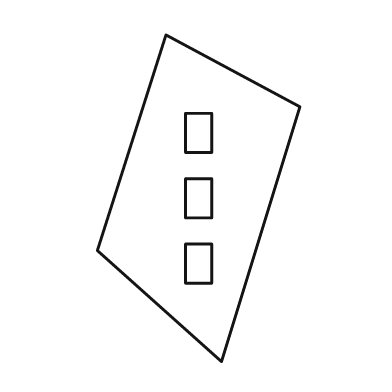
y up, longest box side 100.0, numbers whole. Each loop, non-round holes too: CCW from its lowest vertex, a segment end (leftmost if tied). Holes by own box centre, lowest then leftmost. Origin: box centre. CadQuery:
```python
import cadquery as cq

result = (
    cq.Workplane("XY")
    .moveTo(7.0, -50.0)
    .lineTo(31.0, 28.0)
    .lineTo(-10.0, 50.0)
    .lineTo(-31.0, -16.0)
    .close()
    .moveTo(-4.0, -26.0)
    .lineTo(4.0, -26.0)
    .lineTo(4.0, -14.0)
    .lineTo(-4.0, -14.0)
    .close()
    .moveTo(-4.0, -6.0)
    .lineTo(4.0, -6.0)
    .lineTo(4.0, 6.0)
    .lineTo(-4.0, 6.0)
    .close()
    .moveTo(-4.0, 14.0)
    .lineTo(4.0, 14.0)
    .lineTo(4.0, 26.0)
    .lineTo(-4.0, 26.0)
    .close()
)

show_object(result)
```